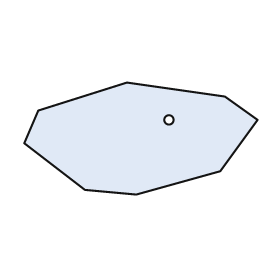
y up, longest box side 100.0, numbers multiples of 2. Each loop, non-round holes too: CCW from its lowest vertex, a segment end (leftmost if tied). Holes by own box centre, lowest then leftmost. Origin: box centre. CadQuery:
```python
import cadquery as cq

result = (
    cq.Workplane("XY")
    .moveTo(-2.0, -24.0)
    .lineTo(34.0, -14.0)
    .lineTo(50.0, 8.0)
    .lineTo(36.0, 18.0)
    .lineTo(-6.0, 24.0)
    .lineTo(-44.0, 12.0)
    .lineTo(-50.0, -2.0)
    .lineTo(-24.0, -22.0)
    .close()
    .moveTo(12.0, 8.0)
    .circle(2.0)
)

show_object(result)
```